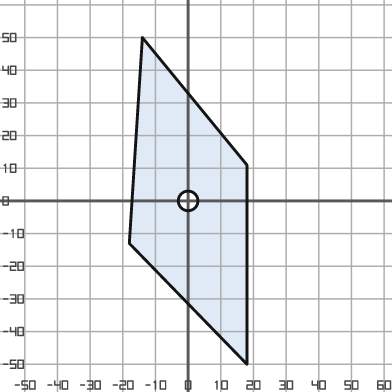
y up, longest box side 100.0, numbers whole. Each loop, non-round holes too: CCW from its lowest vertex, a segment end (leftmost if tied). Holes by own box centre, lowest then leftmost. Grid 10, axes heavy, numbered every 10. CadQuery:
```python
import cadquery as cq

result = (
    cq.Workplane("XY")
    .moveTo(18.0, -50.0)
    .lineTo(18.0, 11.0)
    .lineTo(-14.0, 50.0)
    .lineTo(-18.0, -13.0)
    .close()
    .moveTo(0.0, 0.0)
    .circle(3.0)
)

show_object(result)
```